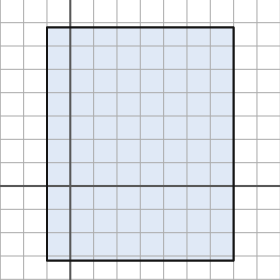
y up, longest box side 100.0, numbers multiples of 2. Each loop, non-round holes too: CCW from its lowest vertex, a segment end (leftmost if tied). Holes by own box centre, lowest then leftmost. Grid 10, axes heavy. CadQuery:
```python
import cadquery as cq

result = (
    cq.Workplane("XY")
    .moveTo(-10.0, -32.0)
    .lineTo(70.0, -32.0)
    .lineTo(70.0, 68.0)
    .lineTo(-10.0, 68.0)
    .close()
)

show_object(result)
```